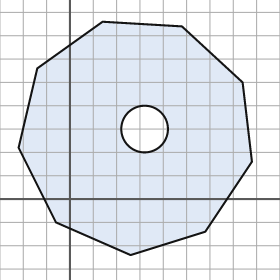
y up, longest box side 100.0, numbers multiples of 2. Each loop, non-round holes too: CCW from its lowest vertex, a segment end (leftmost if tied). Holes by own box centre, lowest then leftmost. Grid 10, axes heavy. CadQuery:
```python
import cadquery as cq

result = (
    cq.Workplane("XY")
    .moveTo(26.0, -24.0)
    .lineTo(58.0, -14.0)
    .lineTo(78.0, 16.0)
    .lineTo(74.0, 50.0)
    .lineTo(48.0, 74.0)
    .lineTo(14.0, 76.0)
    .lineTo(-14.0, 56.0)
    .lineTo(-22.0, 22.0)
    .lineTo(-6.0, -10.0)
    .close()
    .moveTo(32.0, 30.0)
    .circle(10.0)
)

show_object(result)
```